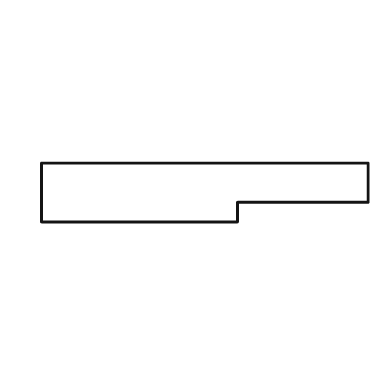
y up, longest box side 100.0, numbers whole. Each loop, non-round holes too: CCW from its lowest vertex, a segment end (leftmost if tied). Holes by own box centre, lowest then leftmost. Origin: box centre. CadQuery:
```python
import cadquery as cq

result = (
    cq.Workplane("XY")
    .moveTo(-50.0, -9.0)
    .lineTo(10.0, -9.0)
    .lineTo(10.0, -3.0)
    .lineTo(50.0, -3.0)
    .lineTo(50.0, 9.0)
    .lineTo(-50.0, 9.0)
    .close()
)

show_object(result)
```